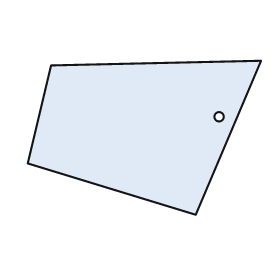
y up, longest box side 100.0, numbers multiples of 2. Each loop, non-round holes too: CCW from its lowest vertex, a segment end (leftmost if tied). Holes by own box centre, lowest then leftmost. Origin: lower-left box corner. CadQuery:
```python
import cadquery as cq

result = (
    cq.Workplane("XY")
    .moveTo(72.0, 0.0)
    .lineTo(100.0, 66.0)
    .lineTo(10.0, 64.0)
    .lineTo(0.0, 22.0)
    .close()
    .moveTo(82.0, 42.0)
    .circle(2.0)
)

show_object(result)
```